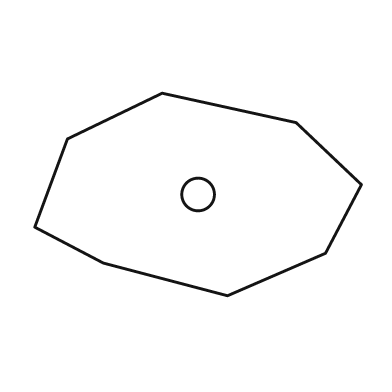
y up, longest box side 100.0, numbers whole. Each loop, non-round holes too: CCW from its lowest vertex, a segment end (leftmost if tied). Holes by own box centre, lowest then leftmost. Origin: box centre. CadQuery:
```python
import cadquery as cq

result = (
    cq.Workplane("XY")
    .moveTo(9.0, -31.0)
    .lineTo(39.0, -18.0)
    .lineTo(50.0, 3.0)
    .lineTo(30.0, 22.0)
    .lineTo(-11.0, 31.0)
    .lineTo(-40.0, 17.0)
    .lineTo(-50.0, -10.0)
    .lineTo(-29.0, -21.0)
    .close()
    .moveTo(0.0, 0.0)
    .circle(5.0)
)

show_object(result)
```